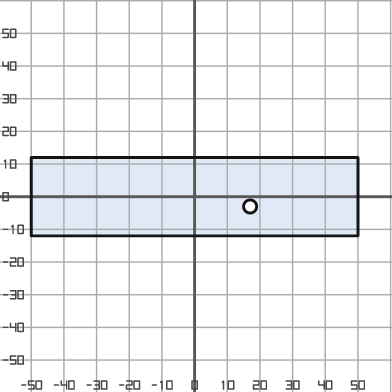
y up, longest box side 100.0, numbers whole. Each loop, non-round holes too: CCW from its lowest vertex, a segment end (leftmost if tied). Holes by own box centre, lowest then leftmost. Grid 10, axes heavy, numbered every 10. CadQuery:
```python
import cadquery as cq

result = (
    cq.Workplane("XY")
    .moveTo(-50.0, -12.0)
    .lineTo(50.0, -12.0)
    .lineTo(50.0, 12.0)
    .lineTo(-50.0, 12.0)
    .close()
    .moveTo(17.0, -3.0)
    .circle(2.0)
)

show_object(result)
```